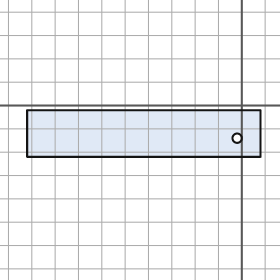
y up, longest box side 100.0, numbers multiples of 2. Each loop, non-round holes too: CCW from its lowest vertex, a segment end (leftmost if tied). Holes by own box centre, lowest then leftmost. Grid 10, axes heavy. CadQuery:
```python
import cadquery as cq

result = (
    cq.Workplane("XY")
    .moveTo(-92.0, -22.0)
    .lineTo(8.0, -22.0)
    .lineTo(8.0, -2.0)
    .lineTo(-92.0, -2.0)
    .close()
    .moveTo(-2.0, -14.0)
    .circle(2.0)
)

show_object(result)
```